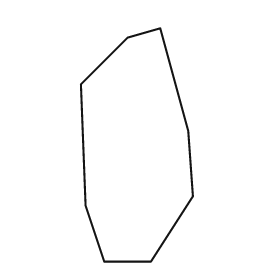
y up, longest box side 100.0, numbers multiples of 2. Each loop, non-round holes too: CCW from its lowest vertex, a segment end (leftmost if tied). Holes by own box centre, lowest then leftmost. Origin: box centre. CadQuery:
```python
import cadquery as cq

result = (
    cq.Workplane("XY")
    .moveTo(-14.0, -50.0)
    .lineTo(6.0, -50.0)
    .lineTo(24.0, -22.0)
    .lineTo(22.0, 6.0)
    .lineTo(10.0, 50.0)
    .lineTo(-4.0, 46.0)
    .lineTo(-24.0, 26.0)
    .lineTo(-22.0, -26.0)
    .close()
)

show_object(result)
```